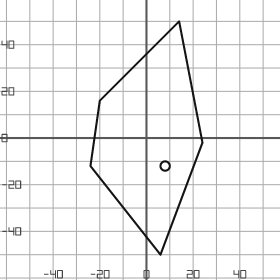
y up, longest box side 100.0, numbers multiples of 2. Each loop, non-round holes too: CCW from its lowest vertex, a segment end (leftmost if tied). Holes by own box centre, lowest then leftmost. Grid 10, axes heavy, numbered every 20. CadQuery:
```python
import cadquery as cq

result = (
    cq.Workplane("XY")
    .moveTo(6.0, -50.0)
    .lineTo(24.0, -2.0)
    .lineTo(14.0, 50.0)
    .lineTo(-20.0, 16.0)
    .lineTo(-24.0, -12.0)
    .close()
    .moveTo(8.0, -12.0)
    .circle(2.0)
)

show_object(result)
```